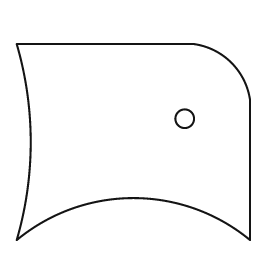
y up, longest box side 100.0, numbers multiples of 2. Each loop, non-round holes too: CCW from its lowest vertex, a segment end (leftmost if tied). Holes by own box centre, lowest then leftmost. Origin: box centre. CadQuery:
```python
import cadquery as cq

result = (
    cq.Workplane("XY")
    .moveTo(-50.0, -42.0)
    .threePointArc((0.0, -24.0), (50.0, -42.0))
    .lineTo(50.0, 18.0)
    .threePointArc((42.0, 34.0), (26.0, 42.0))
    .lineTo(-50.0, 42.0)
    .threePointArc((-44.0, 0.0), (-50.0, -42.0))
    .close()
    .moveTo(22.0, 10.0)
    .circle(4.0)
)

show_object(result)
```